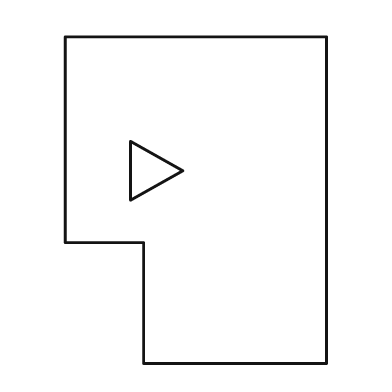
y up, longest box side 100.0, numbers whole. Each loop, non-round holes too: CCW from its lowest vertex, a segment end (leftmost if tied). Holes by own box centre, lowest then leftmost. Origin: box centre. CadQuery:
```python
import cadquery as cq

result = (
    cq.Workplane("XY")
    .moveTo(-16.0, -50.0)
    .lineTo(40.0, -50.0)
    .lineTo(40.0, 50.0)
    .lineTo(-40.0, 50.0)
    .lineTo(-40.0, -13.0)
    .lineTo(-16.0, -13.0)
    .close()
    .moveTo(-20.0, 0.0)
    .lineTo(-4.0, 9.0)
    .lineTo(-20.0, 18.0)
    .close()
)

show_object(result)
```